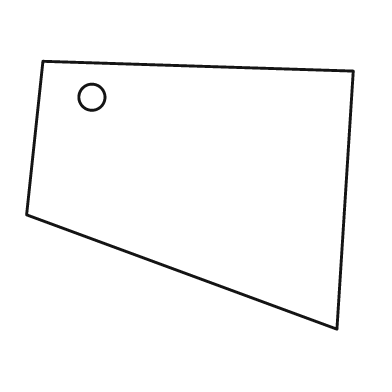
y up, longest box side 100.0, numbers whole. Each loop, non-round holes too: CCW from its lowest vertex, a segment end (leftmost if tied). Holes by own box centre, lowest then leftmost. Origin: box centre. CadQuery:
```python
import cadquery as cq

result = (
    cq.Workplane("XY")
    .moveTo(45.0, -41.0)
    .lineTo(50.0, 38.0)
    .lineTo(-45.0, 41.0)
    .lineTo(-50.0, -6.0)
    .close()
    .moveTo(-30.0, 30.0)
    .circle(4.0)
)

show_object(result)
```